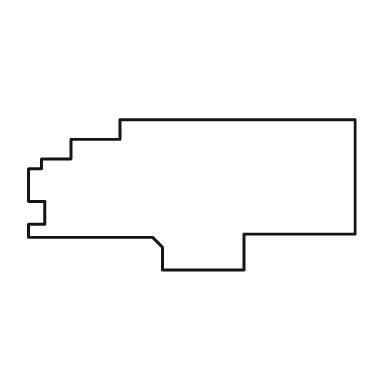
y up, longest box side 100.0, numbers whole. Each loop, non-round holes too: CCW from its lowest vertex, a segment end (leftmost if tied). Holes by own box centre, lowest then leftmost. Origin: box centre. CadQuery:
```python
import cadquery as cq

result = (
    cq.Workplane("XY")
    .moveTo(-9.0, -23.0)
    .lineTo(16.0, -23.0)
    .lineTo(16.0, -12.0)
    .lineTo(50.0, -12.0)
    .lineTo(50.0, 23.0)
    .lineTo(-22.0, 23.0)
    .lineTo(-22.0, 17.0)
    .lineTo(-37.0, 17.0)
    .lineTo(-37.0, 11.0)
    .lineTo(-46.0, 11.0)
    .lineTo(-46.0, 8.0)
    .lineTo(-50.0, 8.0)
    .lineTo(-50.0, -2.0)
    .lineTo(-45.0, -2.0)
    .lineTo(-45.0, -9.0)
    .lineTo(-50.0, -9.0)
    .lineTo(-50.0, -13.0)
    .lineTo(-12.0, -13.0)
    .lineTo(-9.0, -16.0)
    .close()
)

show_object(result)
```